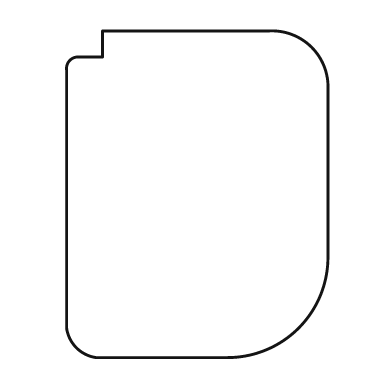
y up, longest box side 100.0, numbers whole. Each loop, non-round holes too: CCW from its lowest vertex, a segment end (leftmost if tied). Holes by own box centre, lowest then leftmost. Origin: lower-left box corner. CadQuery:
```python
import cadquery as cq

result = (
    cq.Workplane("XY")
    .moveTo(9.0, 0.0)
    .lineTo(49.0, 0.0)
    .threePointArc((71.0, 9.0), (80.0, 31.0))
    .lineTo(80.0, 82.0)
    .threePointArc((75.0, 95.0), (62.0, 100.0))
    .lineTo(11.0, 100.0)
    .lineTo(11.0, 92.0)
    .lineTo(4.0, 92.0)
    .threePointArc((1.0, 91.0), (0.0, 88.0))
    .lineTo(0.0, 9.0)
    .threePointArc((3.0, 3.0), (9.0, 0.0))
    .close()
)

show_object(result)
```